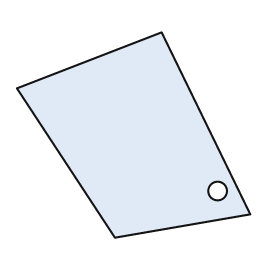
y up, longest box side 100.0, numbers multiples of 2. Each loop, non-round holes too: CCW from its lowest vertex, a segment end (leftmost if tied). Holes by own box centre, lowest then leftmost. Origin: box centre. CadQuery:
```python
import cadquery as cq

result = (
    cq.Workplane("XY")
    .moveTo(-8.0, -44.0)
    .lineTo(50.0, -34.0)
    .lineTo(12.0, 44.0)
    .lineTo(-50.0, 20.0)
    .close()
    .moveTo(36.0, -24.0)
    .circle(4.0)
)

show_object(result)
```